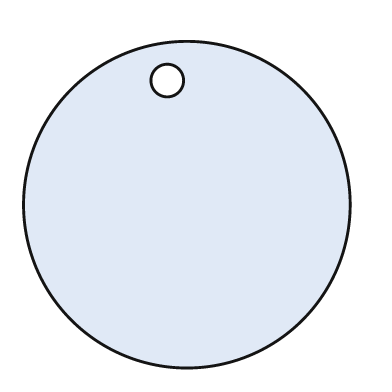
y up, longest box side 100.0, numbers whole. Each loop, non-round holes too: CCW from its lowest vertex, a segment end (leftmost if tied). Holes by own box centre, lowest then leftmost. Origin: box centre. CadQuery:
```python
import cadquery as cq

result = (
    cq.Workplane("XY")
    .moveTo(0.0, 0.0)
    .circle(50.0)
    .moveTo(-6.0, 38.0)
    .circle(5.0)
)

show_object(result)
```